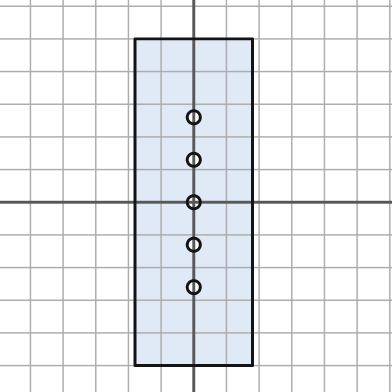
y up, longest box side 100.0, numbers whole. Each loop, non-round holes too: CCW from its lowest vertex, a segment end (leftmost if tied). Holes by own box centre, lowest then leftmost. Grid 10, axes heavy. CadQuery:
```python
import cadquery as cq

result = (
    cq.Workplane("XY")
    .moveTo(-18.0, -50.0)
    .lineTo(18.0, -50.0)
    .lineTo(18.0, 50.0)
    .lineTo(-18.0, 50.0)
    .close()
    .moveTo(0.0, -26.0)
    .circle(2.0)
    .moveTo(0.0, -13.0)
    .circle(2.0)
    .moveTo(0.0, 0.0)
    .circle(2.0)
    .moveTo(0.0, 13.0)
    .circle(2.0)
    .moveTo(0.0, 26.0)
    .circle(2.0)
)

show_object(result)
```